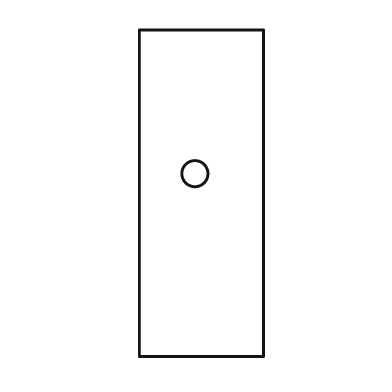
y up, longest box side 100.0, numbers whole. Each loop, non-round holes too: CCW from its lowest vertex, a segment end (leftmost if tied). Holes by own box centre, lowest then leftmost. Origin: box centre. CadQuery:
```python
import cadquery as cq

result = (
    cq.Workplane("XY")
    .moveTo(-19.0, -50.0)
    .lineTo(19.0, -50.0)
    .lineTo(19.0, 50.0)
    .lineTo(-19.0, 50.0)
    .close()
    .moveTo(-2.0, 6.0)
    .circle(4.0)
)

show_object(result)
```